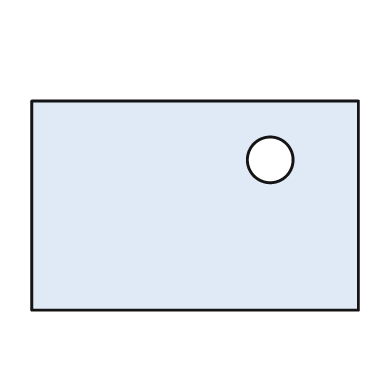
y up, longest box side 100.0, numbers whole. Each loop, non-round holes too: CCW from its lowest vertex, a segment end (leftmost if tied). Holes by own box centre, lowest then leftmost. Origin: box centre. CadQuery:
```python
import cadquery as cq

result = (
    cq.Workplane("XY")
    .moveTo(-50.0, -32.0)
    .lineTo(50.0, -32.0)
    .lineTo(50.0, 32.0)
    .lineTo(-50.0, 32.0)
    .close()
    .moveTo(23.0, 14.0)
    .circle(7.0)
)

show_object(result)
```